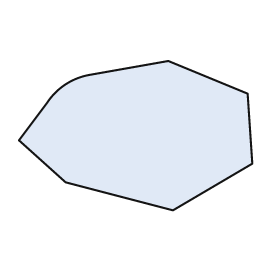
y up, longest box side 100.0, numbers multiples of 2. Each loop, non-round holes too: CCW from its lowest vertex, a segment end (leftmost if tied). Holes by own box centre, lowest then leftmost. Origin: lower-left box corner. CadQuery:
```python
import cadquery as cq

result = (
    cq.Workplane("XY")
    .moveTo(66.0, 0.0)
    .lineTo(100.0, 20.0)
    .lineTo(98.0, 50.0)
    .lineTo(64.0, 64.0)
    .lineTo(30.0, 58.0)
    .threePointArc((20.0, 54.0), (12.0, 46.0))
    .lineTo(0.0, 30.0)
    .lineTo(20.0, 12.0)
    .close()
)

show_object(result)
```